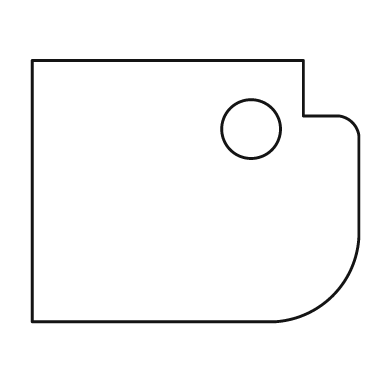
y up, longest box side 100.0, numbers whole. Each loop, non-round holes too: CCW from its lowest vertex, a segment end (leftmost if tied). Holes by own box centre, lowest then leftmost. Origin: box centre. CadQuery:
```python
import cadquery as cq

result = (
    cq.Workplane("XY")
    .moveTo(-50.0, -40.0)
    .lineTo(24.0, -40.0)
    .threePointArc((42.0, -32.0), (50.0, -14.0))
    .lineTo(50.0, 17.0)
    .threePointArc((48.0, 21.0), (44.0, 23.0))
    .lineTo(33.0, 23.0)
    .lineTo(33.0, 40.0)
    .lineTo(-50.0, 40.0)
    .close()
    .moveTo(17.0, 19.0)
    .circle(9.0)
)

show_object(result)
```